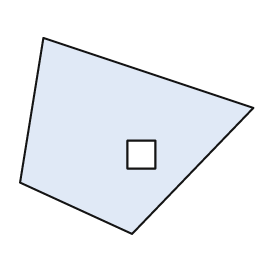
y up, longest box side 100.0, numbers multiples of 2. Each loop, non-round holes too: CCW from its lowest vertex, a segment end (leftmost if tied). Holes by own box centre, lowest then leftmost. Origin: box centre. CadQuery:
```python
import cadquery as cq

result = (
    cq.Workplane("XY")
    .moveTo(-2.0, -42.0)
    .lineTo(50.0, 12.0)
    .lineTo(-40.0, 42.0)
    .lineTo(-50.0, -20.0)
    .close()
    .moveTo(-4.0, -14.0)
    .lineTo(8.0, -14.0)
    .lineTo(8.0, -2.0)
    .lineTo(-4.0, -2.0)
    .close()
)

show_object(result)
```